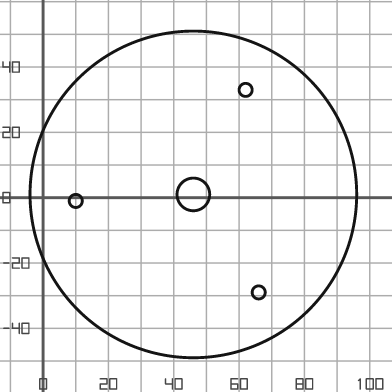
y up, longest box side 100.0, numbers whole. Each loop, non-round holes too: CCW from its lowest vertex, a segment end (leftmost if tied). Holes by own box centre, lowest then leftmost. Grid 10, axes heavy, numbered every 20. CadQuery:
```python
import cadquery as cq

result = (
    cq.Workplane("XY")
    .moveTo(46.0, 1.0)
    .circle(50.0)
    .moveTo(66.0, -29.0)
    .circle(2.0)
    .moveTo(10.0, -1.0)
    .circle(2.0)
    .moveTo(46.0, 1.0)
    .circle(5.0)
    .moveTo(62.0, 33.0)
    .circle(2.0)
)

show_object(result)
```